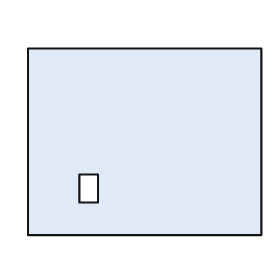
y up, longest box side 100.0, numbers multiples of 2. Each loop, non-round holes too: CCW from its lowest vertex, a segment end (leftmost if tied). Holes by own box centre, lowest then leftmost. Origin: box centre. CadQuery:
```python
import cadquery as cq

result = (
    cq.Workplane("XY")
    .moveTo(-50.0, -40.0)
    .lineTo(50.0, -40.0)
    .lineTo(50.0, 40.0)
    .lineTo(-50.0, 40.0)
    .close()
    .moveTo(-28.0, -26.0)
    .lineTo(-20.0, -26.0)
    .lineTo(-20.0, -14.0)
    .lineTo(-28.0, -14.0)
    .close()
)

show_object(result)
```